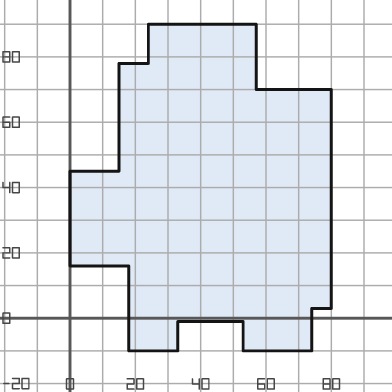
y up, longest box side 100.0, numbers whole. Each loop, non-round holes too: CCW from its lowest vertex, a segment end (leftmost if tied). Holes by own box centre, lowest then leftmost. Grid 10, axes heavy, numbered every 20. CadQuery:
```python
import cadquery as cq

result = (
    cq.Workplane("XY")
    .moveTo(18.0, -10.0)
    .lineTo(33.0, -10.0)
    .lineTo(33.0, -1.0)
    .lineTo(53.0, -1.0)
    .lineTo(53.0, -10.0)
    .lineTo(74.0, -10.0)
    .lineTo(74.0, 3.0)
    .lineTo(80.0, 3.0)
    .lineTo(80.0, 70.0)
    .lineTo(57.0, 70.0)
    .lineTo(57.0, 90.0)
    .lineTo(24.0, 90.0)
    .lineTo(24.0, 78.0)
    .lineTo(15.0, 78.0)
    .lineTo(15.0, 45.0)
    .lineTo(0.0, 45.0)
    .lineTo(0.0, 16.0)
    .lineTo(18.0, 16.0)
    .close()
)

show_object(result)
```